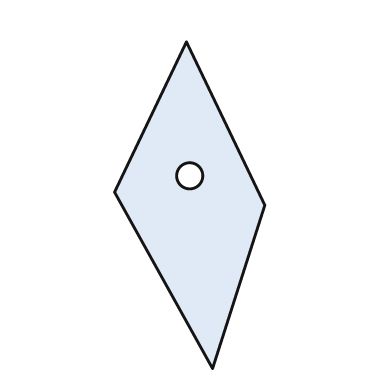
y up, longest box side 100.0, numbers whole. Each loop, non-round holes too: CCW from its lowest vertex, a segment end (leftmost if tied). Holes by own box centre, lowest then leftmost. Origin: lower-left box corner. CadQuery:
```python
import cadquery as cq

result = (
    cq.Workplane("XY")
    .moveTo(30.0, 0.0)
    .lineTo(46.0, 50.0)
    .lineTo(22.0, 100.0)
    .lineTo(0.0, 54.0)
    .close()
    .moveTo(23.0, 59.0)
    .circle(4.0)
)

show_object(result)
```